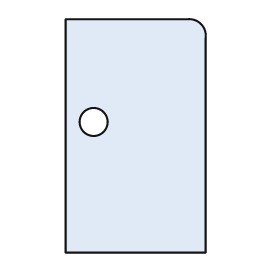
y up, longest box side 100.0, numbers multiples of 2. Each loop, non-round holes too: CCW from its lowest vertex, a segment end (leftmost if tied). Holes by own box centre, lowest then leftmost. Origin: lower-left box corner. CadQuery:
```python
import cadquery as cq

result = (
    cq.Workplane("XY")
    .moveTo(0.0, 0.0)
    .lineTo(60.0, 0.0)
    .lineTo(60.0, 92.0)
    .threePointArc((58.0, 98.0), (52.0, 100.0))
    .lineTo(0.0, 100.0)
    .close()
    .moveTo(12.0, 56.0)
    .circle(6.0)
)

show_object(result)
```